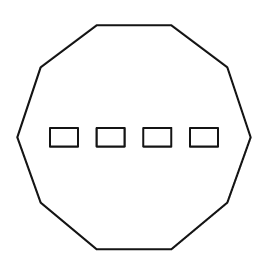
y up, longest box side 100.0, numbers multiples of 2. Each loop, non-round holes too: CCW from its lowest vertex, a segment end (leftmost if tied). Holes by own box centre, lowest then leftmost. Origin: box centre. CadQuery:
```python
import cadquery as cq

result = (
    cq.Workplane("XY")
    .moveTo(-16.0, -48.0)
    .lineTo(16.0, -48.0)
    .lineTo(40.0, -28.0)
    .lineTo(50.0, 0.0)
    .lineTo(40.0, 30.0)
    .lineTo(16.0, 48.0)
    .lineTo(-16.0, 48.0)
    .lineTo(-40.0, 30.0)
    .lineTo(-50.0, 0.0)
    .lineTo(-40.0, -28.0)
    .close()
    .moveTo(-36.0, -4.0)
    .lineTo(-24.0, -4.0)
    .lineTo(-24.0, 4.0)
    .lineTo(-36.0, 4.0)
    .close()
    .moveTo(-16.0, -4.0)
    .lineTo(-4.0, -4.0)
    .lineTo(-4.0, 4.0)
    .lineTo(-16.0, 4.0)
    .close()
    .moveTo(4.0, -4.0)
    .lineTo(16.0, -4.0)
    .lineTo(16.0, 4.0)
    .lineTo(4.0, 4.0)
    .close()
    .moveTo(24.0, -4.0)
    .lineTo(36.0, -4.0)
    .lineTo(36.0, 4.0)
    .lineTo(24.0, 4.0)
    .close()
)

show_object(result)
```